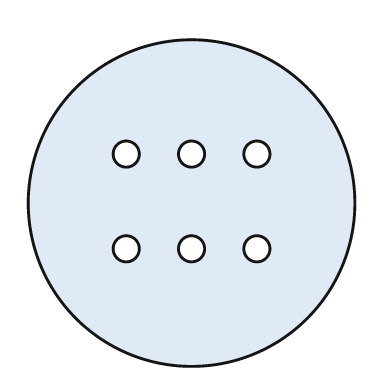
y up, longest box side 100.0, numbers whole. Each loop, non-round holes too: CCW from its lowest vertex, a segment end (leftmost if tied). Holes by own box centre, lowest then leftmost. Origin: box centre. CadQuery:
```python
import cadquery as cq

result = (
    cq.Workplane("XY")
    .moveTo(0.0, 0.0)
    .circle(50.0)
    .moveTo(-20.0, -14.0)
    .circle(4.0)
    .moveTo(0.0, -14.0)
    .circle(4.0)
    .moveTo(20.0, -14.0)
    .circle(4.0)
    .moveTo(-20.0, 15.0)
    .circle(4.0)
    .moveTo(0.0, 15.0)
    .circle(4.0)
    .moveTo(20.0, 15.0)
    .circle(4.0)
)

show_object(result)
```